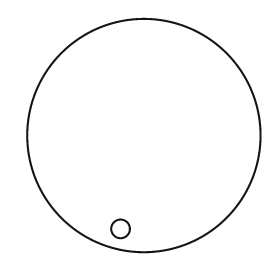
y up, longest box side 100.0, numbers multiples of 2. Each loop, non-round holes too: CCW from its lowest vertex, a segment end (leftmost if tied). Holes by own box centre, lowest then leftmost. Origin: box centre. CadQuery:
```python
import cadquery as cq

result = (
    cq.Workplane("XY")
    .moveTo(0.0, 0.0)
    .circle(50.0)
    .moveTo(-10.0, -40.0)
    .circle(4.0)
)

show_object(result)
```